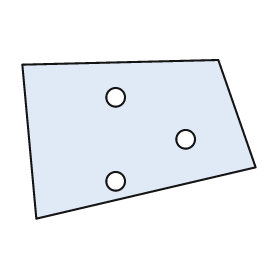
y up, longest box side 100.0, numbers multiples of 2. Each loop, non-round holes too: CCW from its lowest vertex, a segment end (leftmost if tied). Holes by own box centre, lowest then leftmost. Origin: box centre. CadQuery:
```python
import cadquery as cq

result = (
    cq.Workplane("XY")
    .moveTo(-44.0, -34.0)
    .lineTo(50.0, -12.0)
    .lineTo(34.0, 34.0)
    .lineTo(-50.0, 32.0)
    .close()
    .moveTo(-10.0, -18.0)
    .circle(4.0)
    .moveTo(20.0, 0.0)
    .circle(4.0)
    .moveTo(-10.0, 18.0)
    .circle(4.0)
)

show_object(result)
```